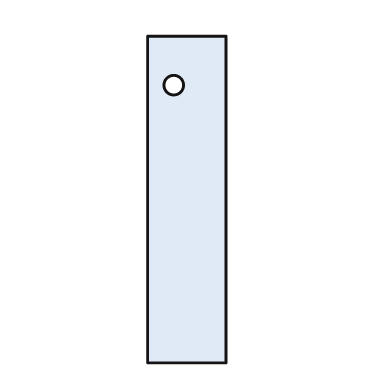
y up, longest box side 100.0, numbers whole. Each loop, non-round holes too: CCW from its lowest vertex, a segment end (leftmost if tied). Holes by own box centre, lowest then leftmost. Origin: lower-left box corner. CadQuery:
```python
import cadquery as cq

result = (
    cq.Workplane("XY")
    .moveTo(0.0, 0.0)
    .lineTo(24.0, 0.0)
    .lineTo(24.0, 100.0)
    .lineTo(0.0, 100.0)
    .close()
    .moveTo(8.0, 85.0)
    .circle(3.0)
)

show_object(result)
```